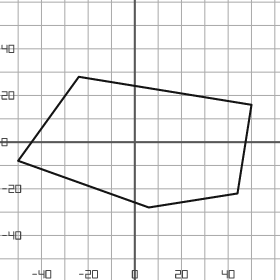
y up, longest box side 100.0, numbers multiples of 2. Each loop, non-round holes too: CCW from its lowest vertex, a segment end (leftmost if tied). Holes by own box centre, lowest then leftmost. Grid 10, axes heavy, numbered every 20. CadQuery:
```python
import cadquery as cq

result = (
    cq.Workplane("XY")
    .moveTo(6.0, -28.0)
    .lineTo(44.0, -22.0)
    .lineTo(50.0, 16.0)
    .lineTo(-24.0, 28.0)
    .lineTo(-50.0, -8.0)
    .close()
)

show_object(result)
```